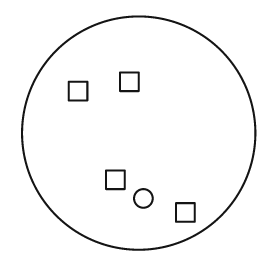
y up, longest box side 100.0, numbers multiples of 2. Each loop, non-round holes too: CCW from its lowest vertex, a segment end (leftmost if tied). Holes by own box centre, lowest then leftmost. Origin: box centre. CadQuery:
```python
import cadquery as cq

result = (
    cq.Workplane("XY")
    .moveTo(0.0, 0.0)
    .circle(50.0)
    .moveTo(16.0, -38.0)
    .lineTo(24.0, -38.0)
    .lineTo(24.0, -30.0)
    .lineTo(16.0, -30.0)
    .close()
    .moveTo(2.0, -28.0)
    .circle(4.0)
    .moveTo(-14.0, -24.0)
    .lineTo(-6.0, -24.0)
    .lineTo(-6.0, -16.0)
    .lineTo(-14.0, -16.0)
    .close()
    .moveTo(-30.0, 14.0)
    .lineTo(-22.0, 14.0)
    .lineTo(-22.0, 22.0)
    .lineTo(-30.0, 22.0)
    .close()
    .moveTo(-8.0, 18.0)
    .lineTo(0.0, 18.0)
    .lineTo(0.0, 26.0)
    .lineTo(-8.0, 26.0)
    .close()
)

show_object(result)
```